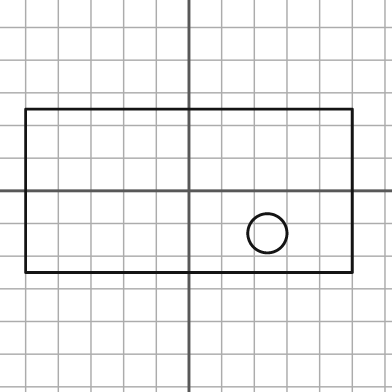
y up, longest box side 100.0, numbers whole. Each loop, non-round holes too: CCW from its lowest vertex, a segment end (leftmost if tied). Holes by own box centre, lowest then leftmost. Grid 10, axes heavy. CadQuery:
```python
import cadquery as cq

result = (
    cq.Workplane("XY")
    .moveTo(-50.0, -25.0)
    .lineTo(50.0, -25.0)
    .lineTo(50.0, 25.0)
    .lineTo(-50.0, 25.0)
    .close()
    .moveTo(24.0, -13.0)
    .circle(6.0)
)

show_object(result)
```